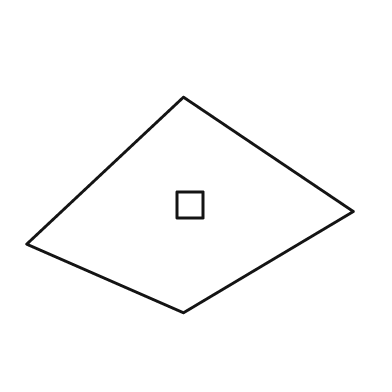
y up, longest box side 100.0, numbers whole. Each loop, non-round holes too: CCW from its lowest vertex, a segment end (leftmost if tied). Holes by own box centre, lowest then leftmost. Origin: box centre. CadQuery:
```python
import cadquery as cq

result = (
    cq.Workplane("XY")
    .moveTo(-2.0, -33.0)
    .lineTo(50.0, -2.0)
    .lineTo(-2.0, 33.0)
    .lineTo(-50.0, -12.0)
    .close()
    .moveTo(-4.0, -4.0)
    .lineTo(4.0, -4.0)
    .lineTo(4.0, 4.0)
    .lineTo(-4.0, 4.0)
    .close()
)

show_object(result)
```